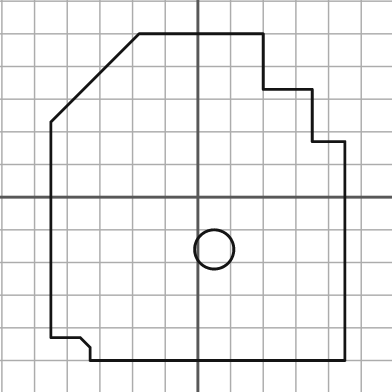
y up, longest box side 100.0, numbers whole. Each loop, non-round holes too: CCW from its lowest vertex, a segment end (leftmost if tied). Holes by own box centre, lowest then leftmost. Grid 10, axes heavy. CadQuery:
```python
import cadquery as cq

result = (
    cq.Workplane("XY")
    .moveTo(-33.0, -50.0)
    .lineTo(45.0, -50.0)
    .lineTo(45.0, 17.0)
    .lineTo(35.0, 17.0)
    .lineTo(35.0, 33.0)
    .lineTo(20.0, 33.0)
    .lineTo(20.0, 50.0)
    .lineTo(-18.0, 50.0)
    .lineTo(-45.0, 23.0)
    .lineTo(-45.0, -43.0)
    .lineTo(-36.0, -43.0)
    .lineTo(-33.0, -46.0)
    .close()
    .moveTo(5.0, -16.0)
    .circle(6.0)
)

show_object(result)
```